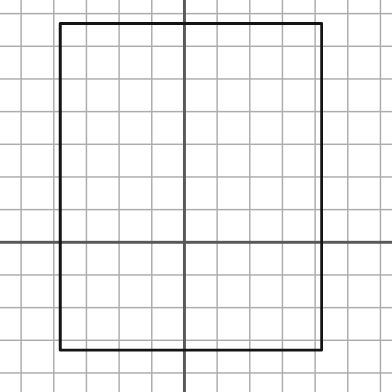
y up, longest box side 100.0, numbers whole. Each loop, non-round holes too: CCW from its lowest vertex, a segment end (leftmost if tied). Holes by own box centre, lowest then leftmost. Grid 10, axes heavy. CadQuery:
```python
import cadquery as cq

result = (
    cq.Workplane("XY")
    .moveTo(-38.0, -33.0)
    .lineTo(42.0, -33.0)
    .lineTo(42.0, 67.0)
    .lineTo(-38.0, 67.0)
    .close()
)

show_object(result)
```